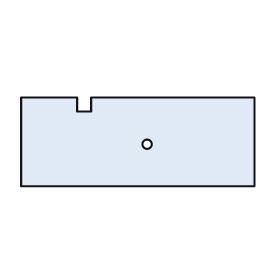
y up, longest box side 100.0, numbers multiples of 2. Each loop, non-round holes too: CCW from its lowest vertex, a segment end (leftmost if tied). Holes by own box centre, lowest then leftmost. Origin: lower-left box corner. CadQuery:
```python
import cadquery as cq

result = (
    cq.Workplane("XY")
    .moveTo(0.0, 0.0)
    .lineTo(100.0, 0.0)
    .lineTo(100.0, 38.0)
    .lineTo(30.0, 38.0)
    .lineTo(30.0, 32.0)
    .lineTo(24.0, 32.0)
    .lineTo(24.0, 38.0)
    .lineTo(0.0, 38.0)
    .close()
    .moveTo(54.0, 18.0)
    .circle(2.0)
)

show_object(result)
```